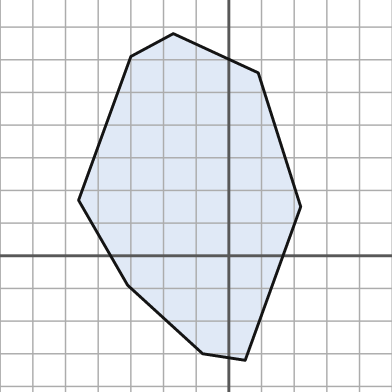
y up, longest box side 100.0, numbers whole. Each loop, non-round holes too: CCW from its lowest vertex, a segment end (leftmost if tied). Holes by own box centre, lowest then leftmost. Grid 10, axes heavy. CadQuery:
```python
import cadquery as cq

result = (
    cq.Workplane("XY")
    .moveTo(5.0, -32.0)
    .lineTo(22.0, 15.0)
    .lineTo(9.0, 56.0)
    .lineTo(-17.0, 68.0)
    .lineTo(-30.0, 61.0)
    .lineTo(-46.0, 17.0)
    .lineTo(-31.0, -9.0)
    .lineTo(-8.0, -30.0)
    .close()
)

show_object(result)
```